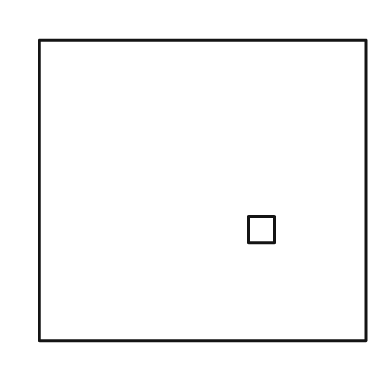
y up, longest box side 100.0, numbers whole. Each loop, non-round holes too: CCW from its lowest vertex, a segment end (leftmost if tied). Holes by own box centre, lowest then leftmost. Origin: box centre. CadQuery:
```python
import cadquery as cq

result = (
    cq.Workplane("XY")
    .moveTo(-50.0, -46.0)
    .lineTo(50.0, -46.0)
    .lineTo(50.0, 46.0)
    .lineTo(-50.0, 46.0)
    .close()
    .moveTo(14.0, -16.0)
    .lineTo(22.0, -16.0)
    .lineTo(22.0, -8.0)
    .lineTo(14.0, -8.0)
    .close()
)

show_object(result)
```